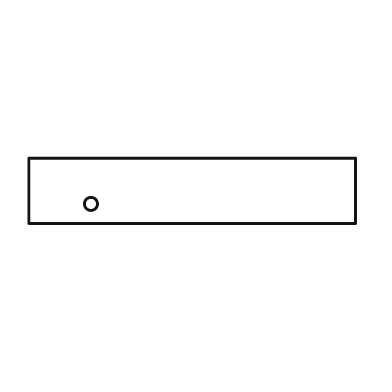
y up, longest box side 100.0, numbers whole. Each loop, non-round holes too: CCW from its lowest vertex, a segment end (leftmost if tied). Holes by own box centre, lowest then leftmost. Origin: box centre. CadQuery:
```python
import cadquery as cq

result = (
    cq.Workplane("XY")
    .moveTo(-50.0, -10.0)
    .lineTo(50.0, -10.0)
    .lineTo(50.0, 10.0)
    .lineTo(-50.0, 10.0)
    .close()
    .moveTo(-31.0, -4.0)
    .circle(2.0)
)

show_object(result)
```